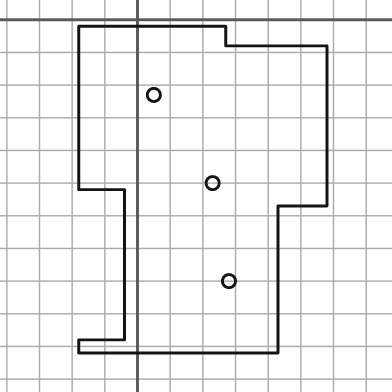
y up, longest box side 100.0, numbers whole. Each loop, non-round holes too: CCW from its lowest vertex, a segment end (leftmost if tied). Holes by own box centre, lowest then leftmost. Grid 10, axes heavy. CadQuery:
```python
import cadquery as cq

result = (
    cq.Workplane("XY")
    .moveTo(-18.0, -102.0)
    .lineTo(43.0, -102.0)
    .lineTo(43.0, -57.0)
    .lineTo(58.0, -57.0)
    .lineTo(58.0, -8.0)
    .lineTo(27.0, -8.0)
    .lineTo(27.0, -2.0)
    .lineTo(-18.0, -2.0)
    .lineTo(-18.0, -52.0)
    .lineTo(-4.0, -52.0)
    .lineTo(-4.0, -98.0)
    .lineTo(-18.0, -98.0)
    .close()
    .moveTo(28.0, -80.0)
    .circle(2.0)
    .moveTo(23.0, -50.0)
    .circle(2.0)
    .moveTo(5.0, -23.0)
    .circle(2.0)
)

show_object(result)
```